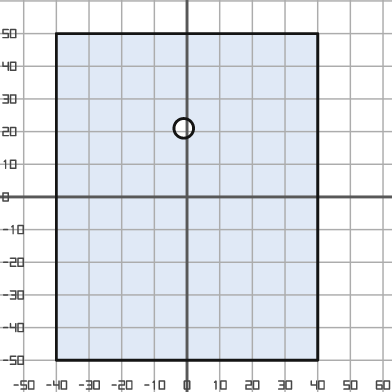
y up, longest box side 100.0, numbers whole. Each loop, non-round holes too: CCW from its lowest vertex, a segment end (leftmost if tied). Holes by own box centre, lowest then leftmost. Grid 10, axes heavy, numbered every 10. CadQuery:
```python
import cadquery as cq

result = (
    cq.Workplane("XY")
    .moveTo(-40.0, -50.0)
    .lineTo(40.0, -50.0)
    .lineTo(40.0, 50.0)
    .lineTo(-40.0, 50.0)
    .close()
    .moveTo(-1.0, 21.0)
    .circle(3.0)
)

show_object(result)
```